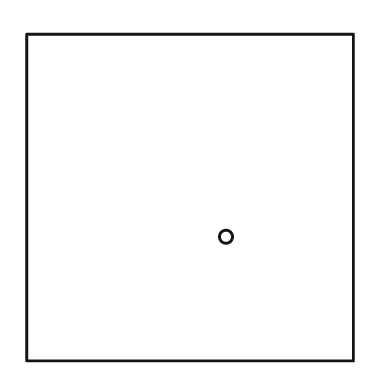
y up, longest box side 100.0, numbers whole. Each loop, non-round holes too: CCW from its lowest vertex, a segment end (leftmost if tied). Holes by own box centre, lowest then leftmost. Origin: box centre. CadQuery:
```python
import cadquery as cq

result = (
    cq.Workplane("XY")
    .moveTo(-50.0, -50.0)
    .lineTo(50.0, -50.0)
    .lineTo(50.0, 50.0)
    .lineTo(-50.0, 50.0)
    .close()
    .moveTo(11.0, -12.0)
    .circle(2.0)
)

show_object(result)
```